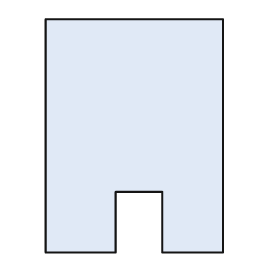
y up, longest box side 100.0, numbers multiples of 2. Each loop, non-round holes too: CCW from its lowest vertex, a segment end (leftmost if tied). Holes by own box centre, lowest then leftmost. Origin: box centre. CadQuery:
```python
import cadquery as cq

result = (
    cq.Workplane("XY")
    .moveTo(-38.0, -50.0)
    .lineTo(-8.0, -50.0)
    .lineTo(-8.0, -24.0)
    .lineTo(12.0, -24.0)
    .lineTo(12.0, -50.0)
    .lineTo(38.0, -50.0)
    .lineTo(38.0, 50.0)
    .lineTo(-38.0, 50.0)
    .close()
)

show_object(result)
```